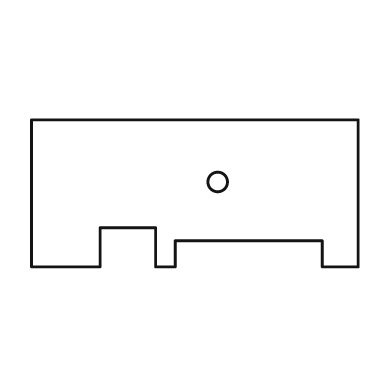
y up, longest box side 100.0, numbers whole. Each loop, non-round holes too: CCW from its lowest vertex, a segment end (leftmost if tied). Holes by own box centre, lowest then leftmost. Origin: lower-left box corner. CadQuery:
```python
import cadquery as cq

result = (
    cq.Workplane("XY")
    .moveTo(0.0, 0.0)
    .lineTo(21.0, 0.0)
    .lineTo(21.0, 12.0)
    .lineTo(38.0, 12.0)
    .lineTo(38.0, 0.0)
    .lineTo(44.0, 0.0)
    .lineTo(44.0, 8.0)
    .lineTo(89.0, 8.0)
    .lineTo(89.0, 0.0)
    .lineTo(100.0, 0.0)
    .lineTo(100.0, 45.0)
    .lineTo(0.0, 45.0)
    .close()
    .moveTo(57.0, 26.0)
    .circle(3.0)
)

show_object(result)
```